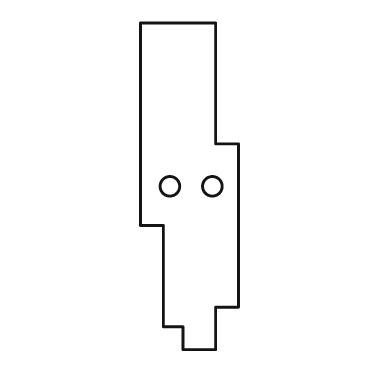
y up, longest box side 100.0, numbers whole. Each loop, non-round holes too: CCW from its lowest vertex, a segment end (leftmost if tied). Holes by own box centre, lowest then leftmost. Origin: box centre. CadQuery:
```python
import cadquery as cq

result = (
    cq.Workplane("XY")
    .moveTo(-2.0, -50.0)
    .lineTo(8.0, -50.0)
    .lineTo(8.0, -37.0)
    .lineTo(15.0, -37.0)
    .lineTo(15.0, 13.0)
    .lineTo(8.0, 13.0)
    .lineTo(8.0, 50.0)
    .lineTo(-15.0, 50.0)
    .lineTo(-15.0, -12.0)
    .lineTo(-8.0, -12.0)
    .lineTo(-8.0, -43.0)
    .lineTo(-2.0, -43.0)
    .close()
    .moveTo(-6.0, 0.0)
    .circle(3.0)
    .moveTo(7.0, 0.0)
    .circle(3.0)
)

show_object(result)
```